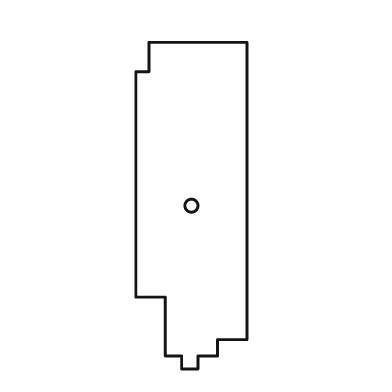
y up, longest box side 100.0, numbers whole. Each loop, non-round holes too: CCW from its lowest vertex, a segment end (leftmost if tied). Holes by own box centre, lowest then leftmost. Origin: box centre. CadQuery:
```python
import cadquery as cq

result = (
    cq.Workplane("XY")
    .moveTo(-3.0, -50.0)
    .lineTo(2.0, -50.0)
    .lineTo(2.0, -46.0)
    .lineTo(8.0, -46.0)
    .lineTo(8.0, -41.0)
    .lineTo(17.0, -41.0)
    .lineTo(17.0, 50.0)
    .lineTo(-13.0, 50.0)
    .lineTo(-13.0, 41.0)
    .lineTo(-17.0, 41.0)
    .lineTo(-17.0, -28.0)
    .lineTo(-8.0, -28.0)
    .lineTo(-8.0, -46.0)
    .lineTo(-3.0, -46.0)
    .close()
    .moveTo(0.0, 0.0)
    .circle(2.0)
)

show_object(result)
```